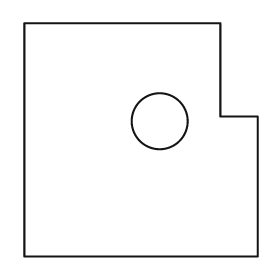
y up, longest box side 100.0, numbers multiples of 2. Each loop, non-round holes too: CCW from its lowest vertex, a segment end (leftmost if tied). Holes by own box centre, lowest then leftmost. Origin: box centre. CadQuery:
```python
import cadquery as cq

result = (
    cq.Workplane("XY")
    .moveTo(-50.0, -50.0)
    .lineTo(50.0, -50.0)
    .lineTo(50.0, 10.0)
    .lineTo(34.0, 10.0)
    .lineTo(34.0, 50.0)
    .lineTo(-50.0, 50.0)
    .close()
    .moveTo(8.0, 8.0)
    .circle(12.0)
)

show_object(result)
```